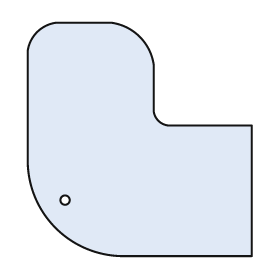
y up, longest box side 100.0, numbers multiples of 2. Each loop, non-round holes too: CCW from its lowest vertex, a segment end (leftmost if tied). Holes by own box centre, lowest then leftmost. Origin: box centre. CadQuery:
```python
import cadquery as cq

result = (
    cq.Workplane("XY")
    .moveTo(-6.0, -50.0)
    .lineTo(48.0, -50.0)
    .lineTo(48.0, 6.0)
    .lineTo(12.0, 6.0)
    .threePointArc((8.0, 8.0), (6.0, 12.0))
    .lineTo(6.0, 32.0)
    .threePointArc((0.0, 44.0), (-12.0, 50.0))
    .lineTo(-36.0, 50.0)
    .threePointArc((-44.0, 46.0), (-48.0, 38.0))
    .lineTo(-48.0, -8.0)
    .threePointArc((-36.0, -38.0), (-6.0, -50.0))
    .close()
    .moveTo(-32.0, -26.0)
    .circle(2.0)
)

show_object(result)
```